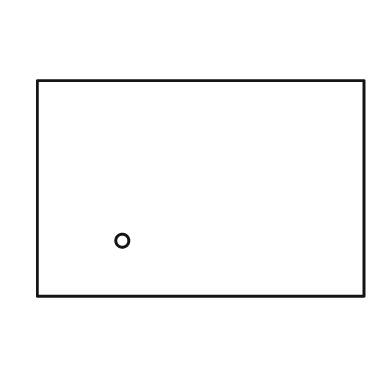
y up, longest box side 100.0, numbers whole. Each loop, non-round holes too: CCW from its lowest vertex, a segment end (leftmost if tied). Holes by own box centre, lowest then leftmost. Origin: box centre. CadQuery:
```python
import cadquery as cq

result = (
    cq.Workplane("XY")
    .moveTo(-50.0, -33.0)
    .lineTo(50.0, -33.0)
    .lineTo(50.0, 33.0)
    .lineTo(-50.0, 33.0)
    .close()
    .moveTo(-24.0, -16.0)
    .circle(2.0)
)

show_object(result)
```